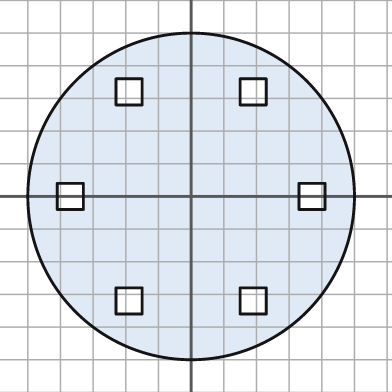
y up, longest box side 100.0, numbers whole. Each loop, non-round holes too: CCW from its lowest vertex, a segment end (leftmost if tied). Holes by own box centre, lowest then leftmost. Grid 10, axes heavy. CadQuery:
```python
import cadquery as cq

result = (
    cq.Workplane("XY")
    .moveTo(0.0, 0.0)
    .circle(50.0)
    .moveTo(-23.0, -36.0)
    .lineTo(-15.0, -36.0)
    .lineTo(-15.0, -28.0)
    .lineTo(-23.0, -28.0)
    .close()
    .moveTo(15.0, -36.0)
    .lineTo(23.0, -36.0)
    .lineTo(23.0, -28.0)
    .lineTo(15.0, -28.0)
    .close()
    .moveTo(-41.0, -4.0)
    .lineTo(-33.0, -4.0)
    .lineTo(-33.0, 4.0)
    .lineTo(-41.0, 4.0)
    .close()
    .moveTo(33.0, -4.0)
    .lineTo(41.0, -4.0)
    .lineTo(41.0, 4.0)
    .lineTo(33.0, 4.0)
    .close()
    .moveTo(-23.0, 28.0)
    .lineTo(-15.0, 28.0)
    .lineTo(-15.0, 36.0)
    .lineTo(-23.0, 36.0)
    .close()
    .moveTo(15.0, 28.0)
    .lineTo(23.0, 28.0)
    .lineTo(23.0, 36.0)
    .lineTo(15.0, 36.0)
    .close()
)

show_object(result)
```